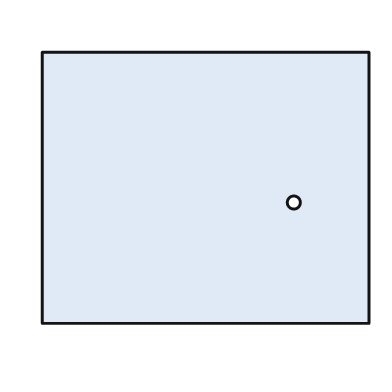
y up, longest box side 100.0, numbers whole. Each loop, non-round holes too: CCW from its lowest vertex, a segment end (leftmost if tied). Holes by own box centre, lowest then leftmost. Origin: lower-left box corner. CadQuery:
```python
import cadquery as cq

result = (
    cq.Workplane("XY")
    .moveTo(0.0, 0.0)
    .lineTo(100.0, 0.0)
    .lineTo(100.0, 83.0)
    .lineTo(0.0, 83.0)
    .close()
    .moveTo(77.0, 37.0)
    .circle(2.0)
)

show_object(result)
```